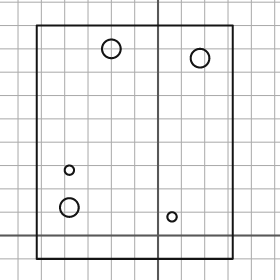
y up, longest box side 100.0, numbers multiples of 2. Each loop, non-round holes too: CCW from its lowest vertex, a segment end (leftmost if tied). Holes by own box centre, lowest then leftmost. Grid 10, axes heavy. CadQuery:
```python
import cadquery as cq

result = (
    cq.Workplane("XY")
    .moveTo(-52.0, -10.0)
    .lineTo(32.0, -10.0)
    .lineTo(32.0, 90.0)
    .lineTo(-52.0, 90.0)
    .close()
    .moveTo(6.0, 8.0)
    .circle(2.0)
    .moveTo(-38.0, 12.0)
    .circle(4.0)
    .moveTo(-38.0, 28.0)
    .circle(2.0)
    .moveTo(18.0, 76.0)
    .circle(4.0)
    .moveTo(-20.0, 80.0)
    .circle(4.0)
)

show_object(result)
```